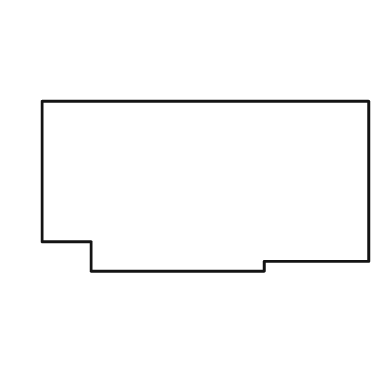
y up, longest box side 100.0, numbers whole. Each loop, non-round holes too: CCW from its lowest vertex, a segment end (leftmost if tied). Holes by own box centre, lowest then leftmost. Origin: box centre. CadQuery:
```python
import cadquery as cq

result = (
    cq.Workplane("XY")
    .moveTo(-35.0, -26.0)
    .lineTo(18.0, -26.0)
    .lineTo(18.0, -23.0)
    .lineTo(50.0, -23.0)
    .lineTo(50.0, 26.0)
    .lineTo(-50.0, 26.0)
    .lineTo(-50.0, -17.0)
    .lineTo(-35.0, -17.0)
    .close()
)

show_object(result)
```